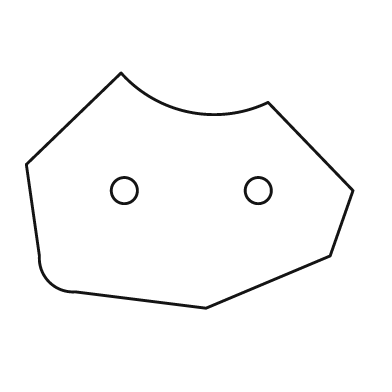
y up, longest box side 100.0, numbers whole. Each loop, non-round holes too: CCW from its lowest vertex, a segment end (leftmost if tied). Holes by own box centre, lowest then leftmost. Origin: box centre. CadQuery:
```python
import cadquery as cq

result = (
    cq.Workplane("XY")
    .moveTo(5.0, -36.0)
    .lineTo(43.0, -20.0)
    .lineTo(50.0, 0.0)
    .lineTo(24.0, 27.0)
    .threePointArc((0.0, 24.0), (-21.0, 36.0))
    .lineTo(-50.0, 8.0)
    .lineTo(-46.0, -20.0)
    .threePointArc((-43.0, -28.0), (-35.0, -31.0))
    .close()
    .moveTo(-20.0, 0.0)
    .circle(4.0)
    .moveTo(21.0, 0.0)
    .circle(4.0)
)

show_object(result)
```